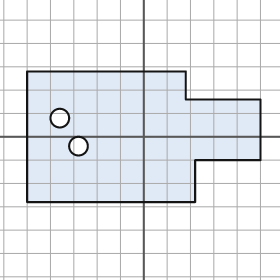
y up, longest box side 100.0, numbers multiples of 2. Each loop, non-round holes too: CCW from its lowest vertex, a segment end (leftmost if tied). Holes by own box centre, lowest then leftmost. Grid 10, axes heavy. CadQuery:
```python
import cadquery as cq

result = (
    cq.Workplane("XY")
    .moveTo(-50.0, -28.0)
    .lineTo(22.0, -28.0)
    .lineTo(22.0, -10.0)
    .lineTo(50.0, -10.0)
    .lineTo(50.0, 16.0)
    .lineTo(18.0, 16.0)
    .lineTo(18.0, 28.0)
    .lineTo(-50.0, 28.0)
    .close()
    .moveTo(-28.0, -4.0)
    .circle(4.0)
    .moveTo(-36.0, 8.0)
    .circle(4.0)
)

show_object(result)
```